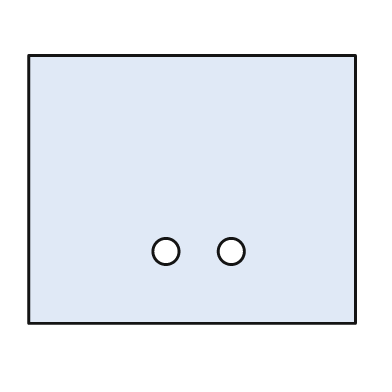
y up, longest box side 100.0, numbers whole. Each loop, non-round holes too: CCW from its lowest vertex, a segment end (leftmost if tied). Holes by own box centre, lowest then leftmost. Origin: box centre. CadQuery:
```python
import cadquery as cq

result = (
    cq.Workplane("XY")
    .moveTo(-50.0, -41.0)
    .lineTo(50.0, -41.0)
    .lineTo(50.0, 41.0)
    .lineTo(-50.0, 41.0)
    .close()
    .moveTo(-8.0, -19.0)
    .circle(4.0)
    .moveTo(12.0, -19.0)
    .circle(4.0)
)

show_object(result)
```